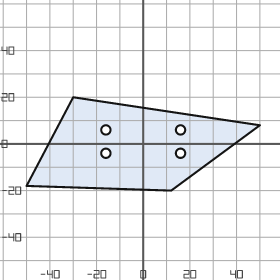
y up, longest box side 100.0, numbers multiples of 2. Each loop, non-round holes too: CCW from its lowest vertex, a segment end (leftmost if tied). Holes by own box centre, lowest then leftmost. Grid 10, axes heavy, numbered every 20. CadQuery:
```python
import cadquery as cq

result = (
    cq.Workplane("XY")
    .moveTo(12.0, -20.0)
    .lineTo(50.0, 8.0)
    .lineTo(-30.0, 20.0)
    .lineTo(-50.0, -18.0)
    .close()
    .moveTo(-16.0, -4.0)
    .circle(2.0)
    .moveTo(16.0, -4.0)
    .circle(2.0)
    .moveTo(-16.0, 6.0)
    .circle(2.0)
    .moveTo(16.0, 6.0)
    .circle(2.0)
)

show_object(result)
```